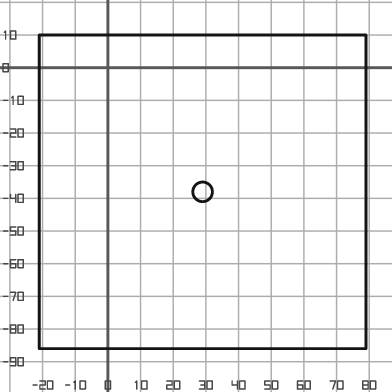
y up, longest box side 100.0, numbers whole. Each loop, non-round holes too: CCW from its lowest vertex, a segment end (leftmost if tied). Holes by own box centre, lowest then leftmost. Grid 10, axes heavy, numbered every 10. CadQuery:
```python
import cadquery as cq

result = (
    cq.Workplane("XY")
    .moveTo(-21.0, -86.0)
    .lineTo(79.0, -86.0)
    .lineTo(79.0, 10.0)
    .lineTo(-21.0, 10.0)
    .close()
    .moveTo(29.0, -38.0)
    .circle(3.0)
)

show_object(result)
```